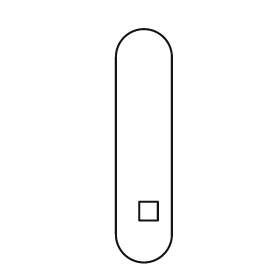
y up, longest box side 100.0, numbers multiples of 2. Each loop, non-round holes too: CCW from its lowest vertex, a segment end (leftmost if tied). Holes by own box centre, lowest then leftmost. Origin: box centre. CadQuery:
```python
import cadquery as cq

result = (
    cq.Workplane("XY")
    .moveTo(-12.0, -38.0)
    .threePointArc((0.0, -50.0), (12.0, -38.0))
    .lineTo(12.0, 38.0)
    .threePointArc((0.0, 50.0), (-12.0, 38.0))
    .close()
    .moveTo(-2.0, -32.0)
    .lineTo(6.0, -32.0)
    .lineTo(6.0, -24.0)
    .lineTo(-2.0, -24.0)
    .close()
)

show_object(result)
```